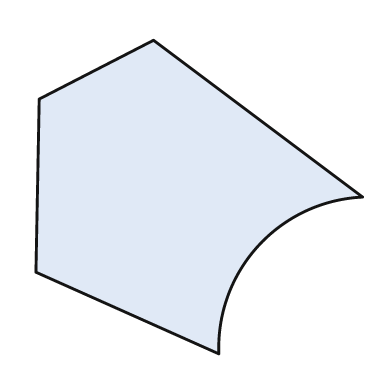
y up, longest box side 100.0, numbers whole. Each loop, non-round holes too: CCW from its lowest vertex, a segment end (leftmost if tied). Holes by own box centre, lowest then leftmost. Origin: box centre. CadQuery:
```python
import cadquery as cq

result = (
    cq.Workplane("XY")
    .moveTo(6.0, -48.0)
    .threePointArc((18.0, -15.0), (50.0, 0.0))
    .lineTo(-14.0, 48.0)
    .lineTo(-49.0, 30.0)
    .lineTo(-50.0, -23.0)
    .close()
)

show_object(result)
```